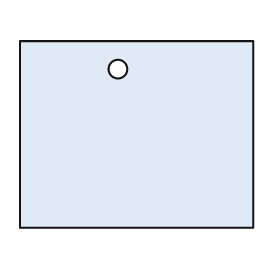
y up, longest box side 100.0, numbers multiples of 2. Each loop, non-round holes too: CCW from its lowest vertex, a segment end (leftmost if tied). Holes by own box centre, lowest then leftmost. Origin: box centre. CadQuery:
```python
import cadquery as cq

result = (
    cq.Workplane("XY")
    .moveTo(-50.0, -40.0)
    .lineTo(50.0, -40.0)
    .lineTo(50.0, 40.0)
    .lineTo(-50.0, 40.0)
    .close()
    .moveTo(-8.0, 28.0)
    .circle(4.0)
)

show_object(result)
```